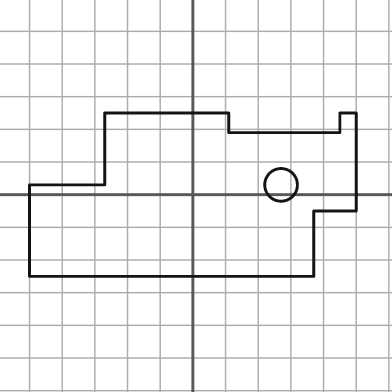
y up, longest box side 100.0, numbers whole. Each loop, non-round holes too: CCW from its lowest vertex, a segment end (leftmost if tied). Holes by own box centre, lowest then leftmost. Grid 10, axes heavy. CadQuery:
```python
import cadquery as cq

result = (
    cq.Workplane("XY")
    .moveTo(-50.0, -25.0)
    .lineTo(37.0, -25.0)
    .lineTo(37.0, -5.0)
    .lineTo(50.0, -5.0)
    .lineTo(50.0, 25.0)
    .lineTo(45.0, 25.0)
    .lineTo(45.0, 19.0)
    .lineTo(11.0, 19.0)
    .lineTo(11.0, 25.0)
    .lineTo(-27.0, 25.0)
    .lineTo(-27.0, 3.0)
    .lineTo(-50.0, 3.0)
    .close()
    .moveTo(27.0, 3.0)
    .circle(5.0)
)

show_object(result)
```